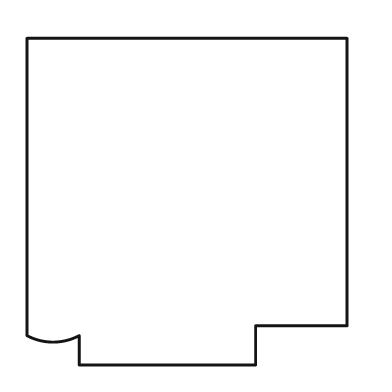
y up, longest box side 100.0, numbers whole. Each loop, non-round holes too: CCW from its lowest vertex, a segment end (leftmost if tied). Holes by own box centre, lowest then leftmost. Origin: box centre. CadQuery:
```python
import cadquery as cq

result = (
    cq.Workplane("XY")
    .moveTo(-33.0, -50.0)
    .lineTo(21.0, -50.0)
    .lineTo(21.0, -38.0)
    .lineTo(49.0, -38.0)
    .lineTo(49.0, 50.0)
    .lineTo(-49.0, 50.0)
    .lineTo(-49.0, -41.0)
    .threePointArc((-41.0, -43.0), (-33.0, -41.0))
    .close()
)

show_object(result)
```